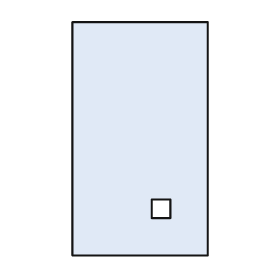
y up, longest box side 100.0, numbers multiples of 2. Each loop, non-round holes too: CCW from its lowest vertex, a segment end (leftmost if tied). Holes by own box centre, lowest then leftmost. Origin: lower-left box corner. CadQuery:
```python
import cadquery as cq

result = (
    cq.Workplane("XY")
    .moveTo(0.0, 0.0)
    .lineTo(58.0, 0.0)
    .lineTo(58.0, 100.0)
    .lineTo(0.0, 100.0)
    .close()
    .moveTo(34.0, 16.0)
    .lineTo(42.0, 16.0)
    .lineTo(42.0, 24.0)
    .lineTo(34.0, 24.0)
    .close()
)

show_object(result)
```